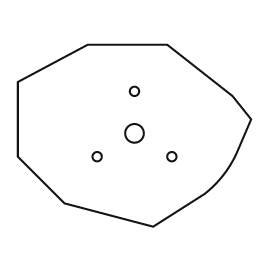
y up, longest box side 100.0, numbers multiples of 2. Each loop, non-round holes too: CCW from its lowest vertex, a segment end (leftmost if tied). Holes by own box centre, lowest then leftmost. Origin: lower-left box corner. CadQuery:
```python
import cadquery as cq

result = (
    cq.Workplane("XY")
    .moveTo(58.0, 0.0)
    .lineTo(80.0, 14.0)
    .threePointArc((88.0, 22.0), (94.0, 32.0))
    .lineTo(100.0, 46.0)
    .lineTo(92.0, 56.0)
    .lineTo(64.0, 78.0)
    .lineTo(30.0, 78.0)
    .lineTo(0.0, 62.0)
    .lineTo(0.0, 30.0)
    .lineTo(20.0, 10.0)
    .close()
    .moveTo(34.0, 30.0)
    .circle(2.0)
    .moveTo(66.0, 30.0)
    .circle(2.0)
    .moveTo(50.0, 40.0)
    .circle(4.0)
    .moveTo(50.0, 58.0)
    .circle(2.0)
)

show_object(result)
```